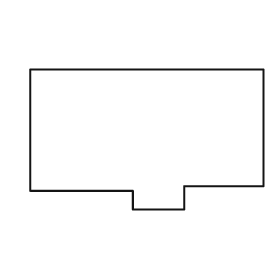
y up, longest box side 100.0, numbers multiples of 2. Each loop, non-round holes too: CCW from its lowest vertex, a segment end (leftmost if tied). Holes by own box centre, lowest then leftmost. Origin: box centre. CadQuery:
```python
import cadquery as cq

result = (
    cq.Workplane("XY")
    .moveTo(-6.0, -30.0)
    .lineTo(16.0, -30.0)
    .lineTo(16.0, -20.0)
    .lineTo(50.0, -20.0)
    .lineTo(50.0, 30.0)
    .lineTo(-50.0, 30.0)
    .lineTo(-50.0, -22.0)
    .lineTo(-6.0, -22.0)
    .close()
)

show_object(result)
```